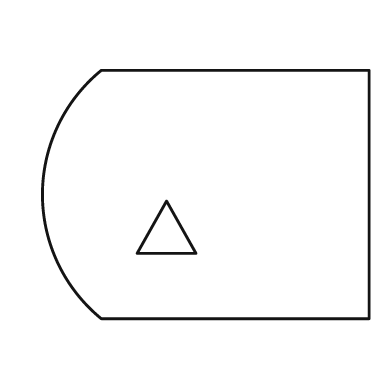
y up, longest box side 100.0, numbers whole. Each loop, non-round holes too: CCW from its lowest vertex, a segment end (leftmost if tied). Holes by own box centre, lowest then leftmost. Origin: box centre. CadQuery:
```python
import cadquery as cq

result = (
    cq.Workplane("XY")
    .moveTo(-32.0, -38.0)
    .lineTo(50.0, -38.0)
    .lineTo(50.0, 38.0)
    .lineTo(-32.0, 38.0)
    .threePointArc((-50.0, 0.0), (-32.0, -38.0))
    .close()
    .moveTo(-21.0, -18.0)
    .lineTo(-3.0, -18.0)
    .lineTo(-12.0, -2.0)
    .close()
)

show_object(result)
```